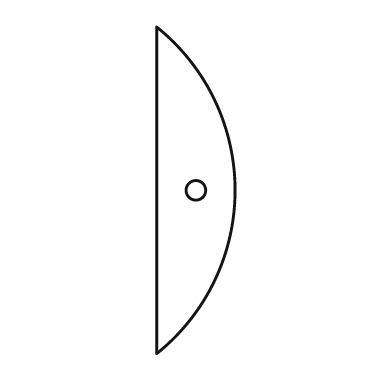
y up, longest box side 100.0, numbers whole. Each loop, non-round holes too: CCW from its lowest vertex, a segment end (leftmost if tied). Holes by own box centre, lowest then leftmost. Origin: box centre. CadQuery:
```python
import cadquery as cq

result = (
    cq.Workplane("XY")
    .moveTo(-12.0, -50.0)
    .threePointArc((12.0, 0.0), (-12.0, 50.0))
    .close()
    .moveTo(0.0, 0.0)
    .circle(3.0)
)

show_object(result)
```